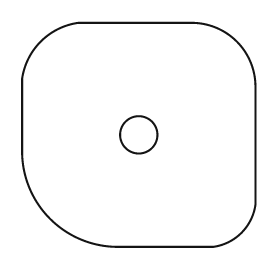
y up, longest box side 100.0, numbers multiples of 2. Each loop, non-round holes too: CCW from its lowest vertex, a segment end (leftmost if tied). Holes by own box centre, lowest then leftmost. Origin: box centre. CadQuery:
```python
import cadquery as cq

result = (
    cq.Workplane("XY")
    .moveTo(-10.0, -48.0)
    .lineTo(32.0, -48.0)
    .threePointArc((44.0, -42.0), (50.0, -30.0))
    .lineTo(50.0, 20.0)
    .threePointArc((42.0, 40.0), (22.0, 48.0))
    .lineTo(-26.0, 48.0)
    .threePointArc((-42.0, 40.0), (-50.0, 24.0))
    .lineTo(-50.0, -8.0)
    .threePointArc((-38.0, -36.0), (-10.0, -48.0))
    .close()
    .moveTo(0.0, 0.0)
    .circle(8.0)
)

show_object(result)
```